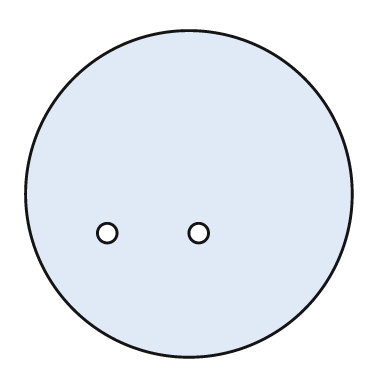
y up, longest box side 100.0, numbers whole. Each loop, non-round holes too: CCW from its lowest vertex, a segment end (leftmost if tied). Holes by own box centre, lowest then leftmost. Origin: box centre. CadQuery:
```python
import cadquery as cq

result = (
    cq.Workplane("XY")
    .moveTo(0.0, 0.0)
    .circle(50.0)
    .moveTo(-25.0, -12.0)
    .circle(3.0)
    .moveTo(3.0, -12.0)
    .circle(3.0)
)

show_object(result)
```